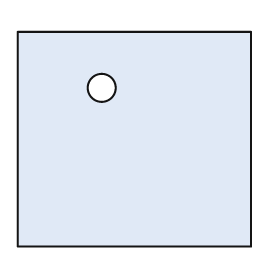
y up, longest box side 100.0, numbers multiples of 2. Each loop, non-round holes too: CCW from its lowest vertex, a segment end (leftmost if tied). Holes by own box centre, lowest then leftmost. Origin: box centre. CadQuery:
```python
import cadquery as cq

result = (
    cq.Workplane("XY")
    .moveTo(-50.0, -46.0)
    .lineTo(50.0, -46.0)
    .lineTo(50.0, 46.0)
    .lineTo(-50.0, 46.0)
    .close()
    .moveTo(-14.0, 22.0)
    .circle(6.0)
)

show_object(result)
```